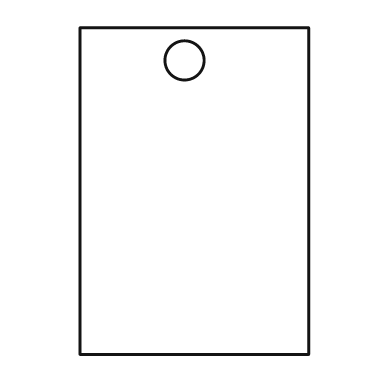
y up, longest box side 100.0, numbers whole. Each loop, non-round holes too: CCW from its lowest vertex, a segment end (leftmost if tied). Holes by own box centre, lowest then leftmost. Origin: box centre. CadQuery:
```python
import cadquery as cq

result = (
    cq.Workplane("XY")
    .moveTo(-35.0, -50.0)
    .lineTo(35.0, -50.0)
    .lineTo(35.0, 50.0)
    .lineTo(-35.0, 50.0)
    .close()
    .moveTo(-3.0, 40.0)
    .circle(6.0)
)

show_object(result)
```